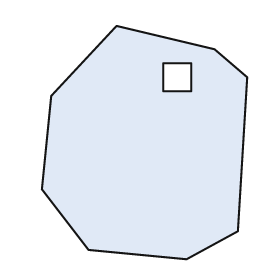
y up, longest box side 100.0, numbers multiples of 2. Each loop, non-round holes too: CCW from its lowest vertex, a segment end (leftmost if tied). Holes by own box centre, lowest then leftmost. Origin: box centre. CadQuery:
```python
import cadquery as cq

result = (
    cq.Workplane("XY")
    .moveTo(18.0, -50.0)
    .lineTo(40.0, -38.0)
    .lineTo(44.0, 28.0)
    .lineTo(30.0, 40.0)
    .lineTo(-12.0, 50.0)
    .lineTo(-40.0, 20.0)
    .lineTo(-44.0, -20.0)
    .lineTo(-24.0, -46.0)
    .close()
    .moveTo(8.0, 22.0)
    .lineTo(20.0, 22.0)
    .lineTo(20.0, 34.0)
    .lineTo(8.0, 34.0)
    .close()
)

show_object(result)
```